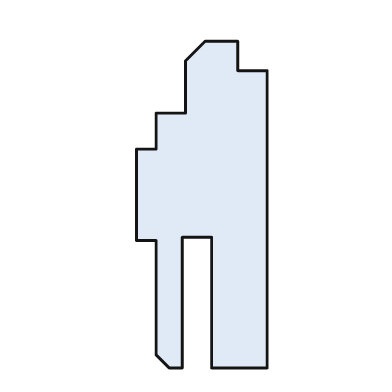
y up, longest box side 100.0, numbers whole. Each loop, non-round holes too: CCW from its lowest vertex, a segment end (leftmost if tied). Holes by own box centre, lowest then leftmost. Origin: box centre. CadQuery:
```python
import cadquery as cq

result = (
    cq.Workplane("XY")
    .moveTo(-10.0, -50.0)
    .lineTo(-6.0, -50.0)
    .lineTo(-6.0, -10.0)
    .lineTo(3.0, -10.0)
    .lineTo(3.0, -50.0)
    .lineTo(20.0, -50.0)
    .lineTo(20.0, 41.0)
    .lineTo(11.0, 41.0)
    .lineTo(11.0, 50.0)
    .lineTo(1.0, 50.0)
    .lineTo(-5.0, 44.0)
    .lineTo(-5.0, 28.0)
    .lineTo(-14.0, 28.0)
    .lineTo(-14.0, 17.0)
    .lineTo(-20.0, 17.0)
    .lineTo(-20.0, -11.0)
    .lineTo(-14.0, -11.0)
    .lineTo(-14.0, -46.0)
    .close()
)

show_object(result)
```